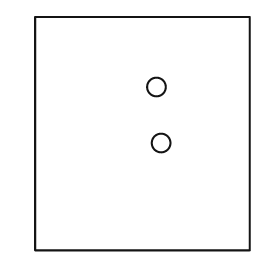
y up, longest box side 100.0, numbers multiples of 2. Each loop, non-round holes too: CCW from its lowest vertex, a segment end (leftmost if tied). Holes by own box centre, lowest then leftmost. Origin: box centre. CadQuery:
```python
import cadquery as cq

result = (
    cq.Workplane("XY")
    .moveTo(-46.0, -50.0)
    .lineTo(46.0, -50.0)
    .lineTo(46.0, 50.0)
    .lineTo(-46.0, 50.0)
    .close()
    .moveTo(8.0, -4.0)
    .circle(4.0)
    .moveTo(6.0, 20.0)
    .circle(4.0)
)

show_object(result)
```